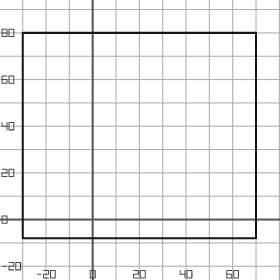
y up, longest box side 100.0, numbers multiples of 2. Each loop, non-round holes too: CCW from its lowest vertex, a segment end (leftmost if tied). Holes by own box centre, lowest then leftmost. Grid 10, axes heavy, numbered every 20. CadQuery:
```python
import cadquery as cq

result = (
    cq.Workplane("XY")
    .moveTo(-30.0, -8.0)
    .lineTo(70.0, -8.0)
    .lineTo(70.0, 80.0)
    .lineTo(-30.0, 80.0)
    .close()
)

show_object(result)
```